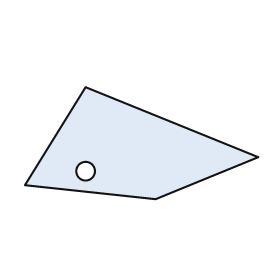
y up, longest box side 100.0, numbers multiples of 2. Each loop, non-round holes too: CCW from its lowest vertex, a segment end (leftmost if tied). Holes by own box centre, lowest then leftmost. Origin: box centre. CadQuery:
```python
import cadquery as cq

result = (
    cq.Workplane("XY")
    .moveTo(6.0, -24.0)
    .lineTo(50.0, -6.0)
    .lineTo(-24.0, 24.0)
    .lineTo(-50.0, -18.0)
    .close()
    .moveTo(-24.0, -12.0)
    .circle(4.0)
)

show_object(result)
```